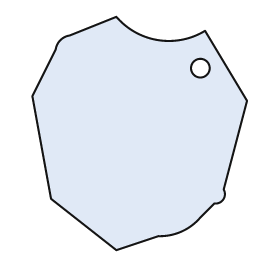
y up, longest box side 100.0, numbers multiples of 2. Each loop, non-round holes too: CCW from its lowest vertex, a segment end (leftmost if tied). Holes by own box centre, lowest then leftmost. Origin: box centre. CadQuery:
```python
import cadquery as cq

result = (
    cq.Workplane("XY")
    .moveTo(-10.0, -50.0)
    .lineTo(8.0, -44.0)
    .threePointArc((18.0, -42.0), (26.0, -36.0))
    .lineTo(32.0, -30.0)
    .threePointArc((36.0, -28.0), (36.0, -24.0))
    .lineTo(46.0, 14.0)
    .lineTo(28.0, 44.0)
    .threePointArc((8.0, 40.0), (-10.0, 50.0))
    .lineTo(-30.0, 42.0)
    .threePointArc((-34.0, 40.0), (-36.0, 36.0))
    .lineTo(-46.0, 16.0)
    .lineTo(-38.0, -28.0)
    .close()
    .moveTo(26.0, 28.0)
    .circle(4.0)
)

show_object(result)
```